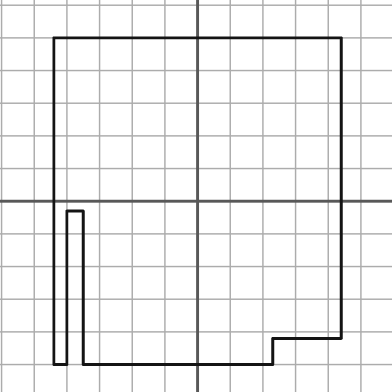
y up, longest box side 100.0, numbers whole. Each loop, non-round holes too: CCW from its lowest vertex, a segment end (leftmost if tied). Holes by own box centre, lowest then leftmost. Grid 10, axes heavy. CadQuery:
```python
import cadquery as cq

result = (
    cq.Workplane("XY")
    .moveTo(-44.0, -50.0)
    .lineTo(-40.0, -50.0)
    .lineTo(-40.0, -3.0)
    .lineTo(-35.0, -3.0)
    .lineTo(-35.0, -50.0)
    .lineTo(23.0, -50.0)
    .lineTo(23.0, -42.0)
    .lineTo(44.0, -42.0)
    .lineTo(44.0, 50.0)
    .lineTo(-44.0, 50.0)
    .close()
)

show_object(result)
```